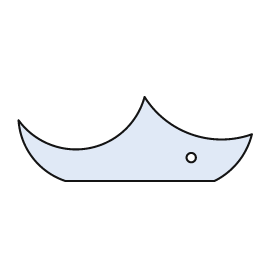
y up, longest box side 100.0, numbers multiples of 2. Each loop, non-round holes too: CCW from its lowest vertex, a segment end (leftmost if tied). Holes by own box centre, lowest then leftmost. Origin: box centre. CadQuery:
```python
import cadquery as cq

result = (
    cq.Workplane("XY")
    .moveTo(-30.0, -18.0)
    .lineTo(34.0, -18.0)
    .threePointArc((44.0, -10.0), (50.0, 2.0))
    .threePointArc((24.0, 2.0), (4.0, 18.0))
    .threePointArc((-20.0, -4.0), (-50.0, 8.0))
    .threePointArc((-44.0, -8.0), (-30.0, -18.0))
    .close()
    .moveTo(24.0, -8.0)
    .circle(2.0)
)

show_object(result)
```